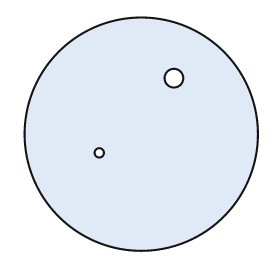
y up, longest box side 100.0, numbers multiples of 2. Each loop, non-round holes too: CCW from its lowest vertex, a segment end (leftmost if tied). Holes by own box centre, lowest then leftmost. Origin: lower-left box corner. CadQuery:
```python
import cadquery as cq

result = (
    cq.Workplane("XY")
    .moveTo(50.0, 50.0)
    .circle(50.0)
    .moveTo(32.0, 42.0)
    .circle(2.0)
    .moveTo(64.0, 74.0)
    .circle(4.0)
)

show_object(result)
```